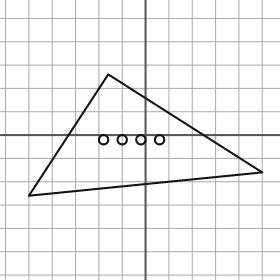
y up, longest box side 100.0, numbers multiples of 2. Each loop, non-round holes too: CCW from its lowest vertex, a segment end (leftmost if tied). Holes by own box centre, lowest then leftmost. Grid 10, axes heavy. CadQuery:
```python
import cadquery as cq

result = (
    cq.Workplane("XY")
    .moveTo(-50.0, -26.0)
    .lineTo(50.0, -16.0)
    .lineTo(-16.0, 26.0)
    .close()
    .moveTo(-18.0, -2.0)
    .circle(2.0)
    .moveTo(-10.0, -2.0)
    .circle(2.0)
    .moveTo(-2.0, -2.0)
    .circle(2.0)
    .moveTo(6.0, -2.0)
    .circle(2.0)
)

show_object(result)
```